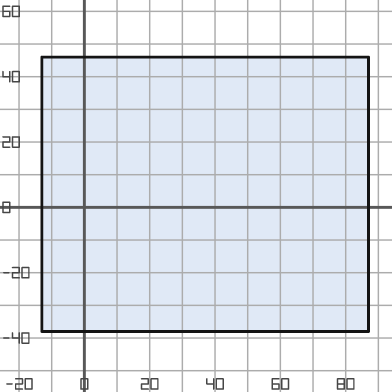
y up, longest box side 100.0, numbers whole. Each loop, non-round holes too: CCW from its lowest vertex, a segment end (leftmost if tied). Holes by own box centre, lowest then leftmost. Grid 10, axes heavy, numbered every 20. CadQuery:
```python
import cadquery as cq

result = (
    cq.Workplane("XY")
    .moveTo(-13.0, -38.0)
    .lineTo(87.0, -38.0)
    .lineTo(87.0, 46.0)
    .lineTo(-13.0, 46.0)
    .close()
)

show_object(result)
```